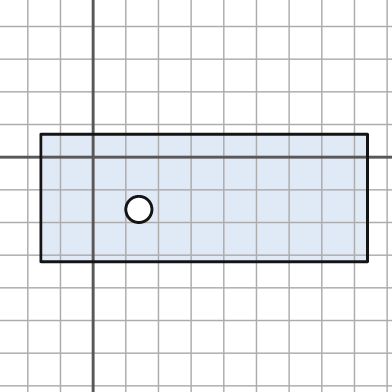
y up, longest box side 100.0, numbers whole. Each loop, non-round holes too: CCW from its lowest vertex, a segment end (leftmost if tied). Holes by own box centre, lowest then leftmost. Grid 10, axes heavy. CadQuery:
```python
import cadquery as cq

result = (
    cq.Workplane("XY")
    .moveTo(-16.0, -32.0)
    .lineTo(84.0, -32.0)
    .lineTo(84.0, 7.0)
    .lineTo(-16.0, 7.0)
    .close()
    .moveTo(14.0, -16.0)
    .circle(4.0)
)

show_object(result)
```